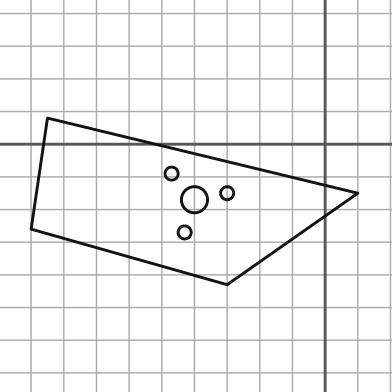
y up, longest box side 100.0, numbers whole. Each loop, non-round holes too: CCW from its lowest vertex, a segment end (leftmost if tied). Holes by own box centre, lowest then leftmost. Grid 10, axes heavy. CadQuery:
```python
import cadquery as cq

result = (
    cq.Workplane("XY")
    .moveTo(-30.0, -43.0)
    .lineTo(10.0, -15.0)
    .lineTo(-85.0, 8.0)
    .lineTo(-90.0, -26.0)
    .close()
    .moveTo(-43.0, -27.0)
    .circle(2.0)
    .moveTo(-40.0, -17.0)
    .circle(4.0)
    .moveTo(-30.0, -15.0)
    .circle(2.0)
    .moveTo(-47.0, -9.0)
    .circle(2.0)
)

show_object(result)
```